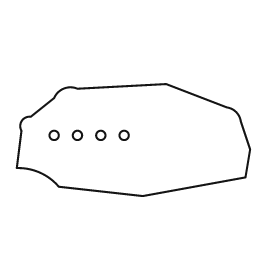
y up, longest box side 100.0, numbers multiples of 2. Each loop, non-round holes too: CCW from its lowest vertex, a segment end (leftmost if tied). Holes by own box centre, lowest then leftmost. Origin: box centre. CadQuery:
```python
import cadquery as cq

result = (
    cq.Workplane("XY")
    .moveTo(4.0, -24.0)
    .lineTo(48.0, -16.0)
    .lineTo(50.0, -4.0)
    .lineTo(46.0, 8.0)
    .threePointArc((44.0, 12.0), (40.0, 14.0))
    .lineTo(14.0, 24.0)
    .lineTo(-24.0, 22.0)
    .threePointArc((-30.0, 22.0), (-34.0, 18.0))
    .lineTo(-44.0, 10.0)
    .threePointArc((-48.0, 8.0), (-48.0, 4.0))
    .lineTo(-50.0, -12.0)
    .threePointArc((-40.0, -14.0), (-32.0, -20.0))
    .close()
    .moveTo(-34.0, 2.0)
    .circle(2.0)
    .moveTo(-24.0, 2.0)
    .circle(2.0)
    .moveTo(-14.0, 2.0)
    .circle(2.0)
    .moveTo(-4.0, 2.0)
    .circle(2.0)
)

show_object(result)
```